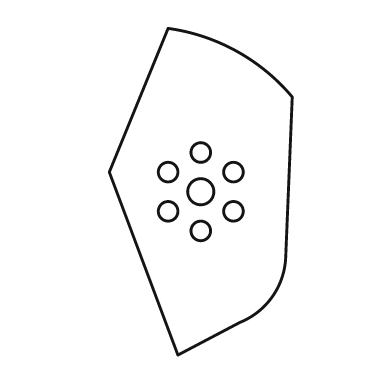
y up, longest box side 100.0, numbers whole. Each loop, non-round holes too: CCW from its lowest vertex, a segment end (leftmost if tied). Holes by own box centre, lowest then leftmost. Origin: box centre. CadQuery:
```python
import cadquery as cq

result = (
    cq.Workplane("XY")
    .moveTo(-7.0, -50.0)
    .lineTo(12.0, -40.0)
    .threePointArc((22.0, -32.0), (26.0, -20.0))
    .lineTo(28.0, 29.0)
    .threePointArc((11.0, 43.0), (-10.0, 50.0))
    .lineTo(-28.0, 6.0)
    .close()
    .moveTo(0.0, -12.0)
    .circle(3.0)
    .moveTo(-10.0, -6.0)
    .circle(3.0)
    .moveTo(10.0, -6.0)
    .circle(3.0)
    .moveTo(0.0, 0.0)
    .circle(4.0)
    .moveTo(-10.0, 6.0)
    .circle(3.0)
    .moveTo(10.0, 6.0)
    .circle(3.0)
    .moveTo(0.0, 12.0)
    .circle(3.0)
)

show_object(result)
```